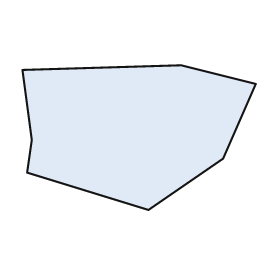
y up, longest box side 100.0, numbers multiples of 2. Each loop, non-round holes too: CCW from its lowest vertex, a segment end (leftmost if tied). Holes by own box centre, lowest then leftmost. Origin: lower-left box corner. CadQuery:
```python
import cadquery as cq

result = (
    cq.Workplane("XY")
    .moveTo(54.0, 0.0)
    .lineTo(86.0, 22.0)
    .lineTo(100.0, 54.0)
    .lineTo(68.0, 62.0)
    .lineTo(0.0, 60.0)
    .lineTo(4.0, 30.0)
    .lineTo(2.0, 16.0)
    .close()
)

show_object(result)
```